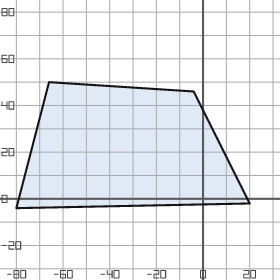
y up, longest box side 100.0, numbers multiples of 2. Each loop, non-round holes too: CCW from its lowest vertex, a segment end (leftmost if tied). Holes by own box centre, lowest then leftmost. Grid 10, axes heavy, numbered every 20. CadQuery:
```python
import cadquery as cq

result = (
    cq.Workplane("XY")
    .moveTo(-80.0, -4.0)
    .lineTo(20.0, -2.0)
    .lineTo(-4.0, 46.0)
    .lineTo(-66.0, 50.0)
    .close()
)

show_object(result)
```